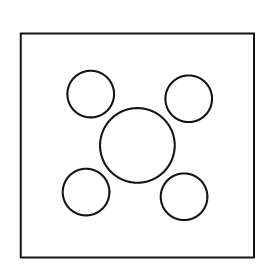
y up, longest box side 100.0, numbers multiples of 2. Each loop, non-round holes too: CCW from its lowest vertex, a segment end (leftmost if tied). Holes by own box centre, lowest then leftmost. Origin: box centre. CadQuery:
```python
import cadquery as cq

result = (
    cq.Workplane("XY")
    .moveTo(-50.0, -48.0)
    .lineTo(50.0, -48.0)
    .lineTo(50.0, 48.0)
    .lineTo(-50.0, 48.0)
    .close()
    .moveTo(20.0, -22.0)
    .circle(10.0)
    .moveTo(-22.0, -20.0)
    .circle(10.0)
    .moveTo(0.0, 0.0)
    .circle(16.0)
    .moveTo(22.0, 20.0)
    .circle(10.0)
    .moveTo(-20.0, 22.0)
    .circle(10.0)
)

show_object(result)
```